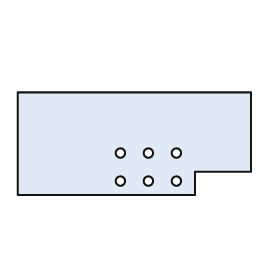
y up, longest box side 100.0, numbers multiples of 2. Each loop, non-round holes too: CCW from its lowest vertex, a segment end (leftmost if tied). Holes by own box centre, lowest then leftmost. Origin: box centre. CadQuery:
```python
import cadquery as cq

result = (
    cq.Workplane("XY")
    .moveTo(-50.0, -22.0)
    .lineTo(26.0, -22.0)
    .lineTo(26.0, -12.0)
    .lineTo(50.0, -12.0)
    .lineTo(50.0, 22.0)
    .lineTo(-50.0, 22.0)
    .close()
    .moveTo(-6.0, -16.0)
    .circle(2.0)
    .moveTo(6.0, -16.0)
    .circle(2.0)
    .moveTo(18.0, -16.0)
    .circle(2.0)
    .moveTo(-6.0, -4.0)
    .circle(2.0)
    .moveTo(6.0, -4.0)
    .circle(2.0)
    .moveTo(18.0, -4.0)
    .circle(2.0)
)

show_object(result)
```